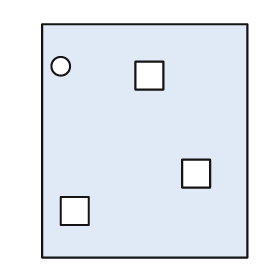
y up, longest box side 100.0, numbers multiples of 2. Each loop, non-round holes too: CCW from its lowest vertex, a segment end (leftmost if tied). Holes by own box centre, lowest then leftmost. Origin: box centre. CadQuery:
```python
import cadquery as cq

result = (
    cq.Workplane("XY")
    .moveTo(-44.0, -50.0)
    .lineTo(44.0, -50.0)
    .lineTo(44.0, 50.0)
    .lineTo(-44.0, 50.0)
    .close()
    .moveTo(-36.0, -36.0)
    .lineTo(-24.0, -36.0)
    .lineTo(-24.0, -24.0)
    .lineTo(-36.0, -24.0)
    .close()
    .moveTo(16.0, -20.0)
    .lineTo(28.0, -20.0)
    .lineTo(28.0, -8.0)
    .lineTo(16.0, -8.0)
    .close()
    .moveTo(-4.0, 22.0)
    .lineTo(8.0, 22.0)
    .lineTo(8.0, 34.0)
    .lineTo(-4.0, 34.0)
    .close()
    .moveTo(-36.0, 32.0)
    .circle(4.0)
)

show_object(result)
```